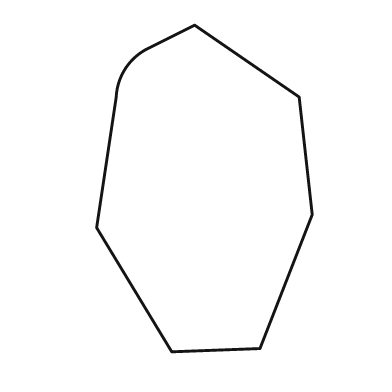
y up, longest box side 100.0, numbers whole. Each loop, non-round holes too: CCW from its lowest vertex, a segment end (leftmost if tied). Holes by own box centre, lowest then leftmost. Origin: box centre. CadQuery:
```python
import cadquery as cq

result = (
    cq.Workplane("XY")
    .moveTo(-10.0, -50.0)
    .lineTo(17.0, -49.0)
    .lineTo(33.0, -8.0)
    .lineTo(29.0, 28.0)
    .lineTo(-3.0, 50.0)
    .lineTo(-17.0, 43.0)
    .threePointArc((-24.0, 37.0), (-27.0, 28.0))
    .lineTo(-33.0, -12.0)
    .close()
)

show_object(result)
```